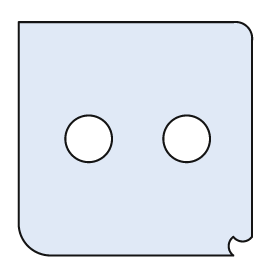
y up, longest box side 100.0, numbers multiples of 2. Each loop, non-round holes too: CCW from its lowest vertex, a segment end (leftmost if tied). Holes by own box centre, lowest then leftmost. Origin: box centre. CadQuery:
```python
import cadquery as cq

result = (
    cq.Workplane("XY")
    .moveTo(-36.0, -50.0)
    .lineTo(42.0, -50.0)
    .threePointArc((40.0, -46.0), (42.0, -42.0))
    .threePointArc((46.0, -44.0), (50.0, -42.0))
    .lineTo(50.0, 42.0)
    .threePointArc((48.0, 48.0), (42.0, 50.0))
    .lineTo(-50.0, 50.0)
    .lineTo(-50.0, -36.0)
    .threePointArc((-46.0, -46.0), (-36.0, -50.0))
    .close()
    .moveTo(-20.0, 0.0)
    .circle(10.0)
    .moveTo(22.0, 0.0)
    .circle(10.0)
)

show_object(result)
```